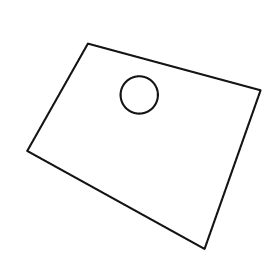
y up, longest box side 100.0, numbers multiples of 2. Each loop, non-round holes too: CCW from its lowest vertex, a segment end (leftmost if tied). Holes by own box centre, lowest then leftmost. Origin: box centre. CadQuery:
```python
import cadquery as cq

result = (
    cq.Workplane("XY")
    .moveTo(26.0, -44.0)
    .lineTo(50.0, 24.0)
    .lineTo(-24.0, 44.0)
    .lineTo(-50.0, -2.0)
    .close()
    .moveTo(-2.0, 22.0)
    .circle(8.0)
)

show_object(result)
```